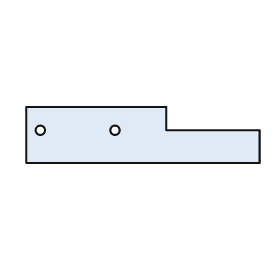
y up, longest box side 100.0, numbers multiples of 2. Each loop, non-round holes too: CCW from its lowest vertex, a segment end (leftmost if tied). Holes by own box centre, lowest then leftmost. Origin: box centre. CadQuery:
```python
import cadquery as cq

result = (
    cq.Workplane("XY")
    .moveTo(-50.0, -12.0)
    .lineTo(50.0, -12.0)
    .lineTo(50.0, 2.0)
    .lineTo(10.0, 2.0)
    .lineTo(10.0, 12.0)
    .lineTo(-50.0, 12.0)
    .close()
    .moveTo(-44.0, 2.0)
    .circle(2.0)
    .moveTo(-12.0, 2.0)
    .circle(2.0)
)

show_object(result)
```